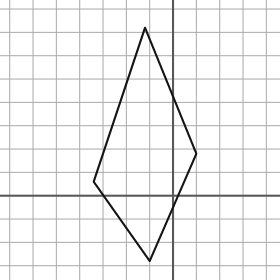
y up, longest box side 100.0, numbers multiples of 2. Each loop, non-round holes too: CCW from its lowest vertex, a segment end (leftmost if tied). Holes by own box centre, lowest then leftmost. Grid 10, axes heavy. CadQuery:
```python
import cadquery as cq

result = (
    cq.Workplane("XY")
    .moveTo(-10.0, -28.0)
    .lineTo(10.0, 18.0)
    .lineTo(-12.0, 72.0)
    .lineTo(-34.0, 6.0)
    .close()
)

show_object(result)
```